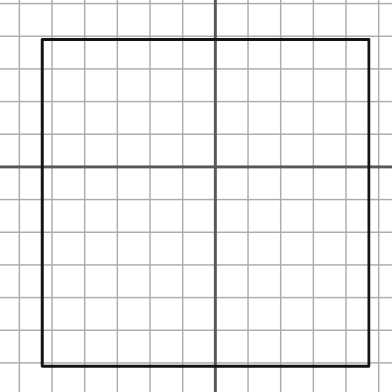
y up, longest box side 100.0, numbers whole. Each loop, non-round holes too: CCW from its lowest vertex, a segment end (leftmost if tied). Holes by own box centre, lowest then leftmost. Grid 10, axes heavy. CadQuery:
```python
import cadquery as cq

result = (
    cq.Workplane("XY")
    .moveTo(-53.0, -61.0)
    .lineTo(47.0, -61.0)
    .lineTo(47.0, 39.0)
    .lineTo(-53.0, 39.0)
    .close()
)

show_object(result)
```